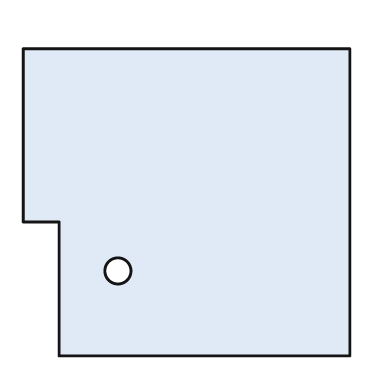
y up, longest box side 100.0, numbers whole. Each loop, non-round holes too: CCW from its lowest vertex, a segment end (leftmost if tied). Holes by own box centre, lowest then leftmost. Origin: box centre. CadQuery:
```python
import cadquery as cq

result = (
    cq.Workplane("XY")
    .moveTo(-39.0, -47.0)
    .lineTo(50.0, -47.0)
    .lineTo(50.0, 47.0)
    .lineTo(-50.0, 47.0)
    .lineTo(-50.0, -6.0)
    .lineTo(-39.0, -6.0)
    .close()
    .moveTo(-21.0, -21.0)
    .circle(4.0)
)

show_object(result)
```